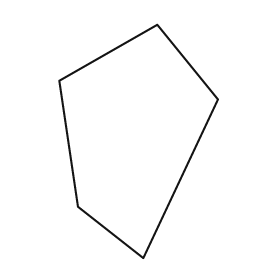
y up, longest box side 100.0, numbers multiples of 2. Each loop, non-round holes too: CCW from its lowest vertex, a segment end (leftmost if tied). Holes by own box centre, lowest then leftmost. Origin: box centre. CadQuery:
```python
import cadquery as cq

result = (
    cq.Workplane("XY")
    .moveTo(2.0, -50.0)
    .lineTo(34.0, 18.0)
    .lineTo(8.0, 50.0)
    .lineTo(-34.0, 26.0)
    .lineTo(-26.0, -28.0)
    .close()
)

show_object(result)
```